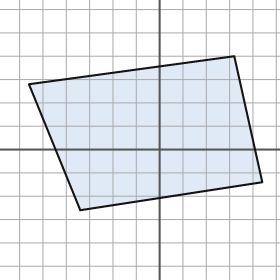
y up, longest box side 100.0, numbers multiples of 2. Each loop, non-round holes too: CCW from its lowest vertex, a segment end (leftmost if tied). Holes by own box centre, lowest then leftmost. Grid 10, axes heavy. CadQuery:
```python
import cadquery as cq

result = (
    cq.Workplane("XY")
    .moveTo(-34.0, -26.0)
    .lineTo(44.0, -14.0)
    .lineTo(32.0, 40.0)
    .lineTo(-56.0, 28.0)
    .close()
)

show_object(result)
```